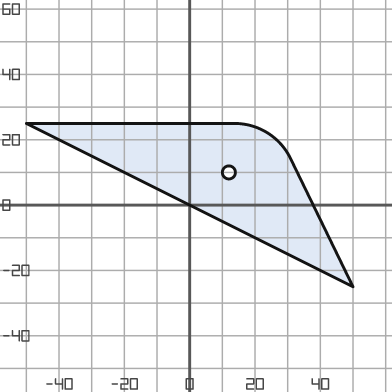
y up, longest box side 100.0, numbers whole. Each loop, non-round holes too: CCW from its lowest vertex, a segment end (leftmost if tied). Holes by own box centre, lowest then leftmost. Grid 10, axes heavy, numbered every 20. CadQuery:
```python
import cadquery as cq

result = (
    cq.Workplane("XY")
    .moveTo(50.0, -25.0)
    .lineTo(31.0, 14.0)
    .threePointArc((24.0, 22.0), (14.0, 25.0))
    .lineTo(-50.0, 25.0)
    .close()
    .moveTo(12.0, 10.0)
    .circle(2.0)
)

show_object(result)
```